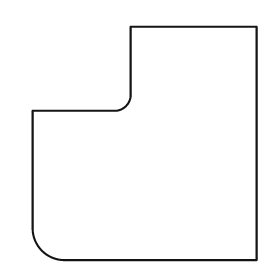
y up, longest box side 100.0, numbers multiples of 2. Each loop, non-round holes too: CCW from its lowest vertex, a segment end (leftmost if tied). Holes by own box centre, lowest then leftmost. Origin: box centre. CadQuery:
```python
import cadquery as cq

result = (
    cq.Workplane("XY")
    .moveTo(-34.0, -50.0)
    .lineTo(48.0, -50.0)
    .lineTo(48.0, 50.0)
    .lineTo(-6.0, 50.0)
    .lineTo(-6.0, 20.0)
    .threePointArc((-8.0, 16.0), (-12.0, 14.0))
    .lineTo(-48.0, 14.0)
    .lineTo(-48.0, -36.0)
    .threePointArc((-44.0, -46.0), (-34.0, -50.0))
    .close()
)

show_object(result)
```